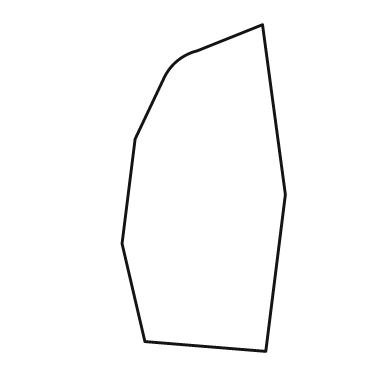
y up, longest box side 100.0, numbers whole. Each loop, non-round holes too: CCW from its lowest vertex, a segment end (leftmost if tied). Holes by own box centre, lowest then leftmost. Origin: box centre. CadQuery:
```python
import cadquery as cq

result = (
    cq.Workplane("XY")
    .moveTo(19.0, -50.0)
    .lineTo(25.0, -2.0)
    .lineTo(18.0, 50.0)
    .lineTo(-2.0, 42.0)
    .threePointArc((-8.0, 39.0), (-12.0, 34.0))
    .lineTo(-21.0, 15.0)
    .lineTo(-25.0, -17.0)
    .lineTo(-18.0, -47.0)
    .close()
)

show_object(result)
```